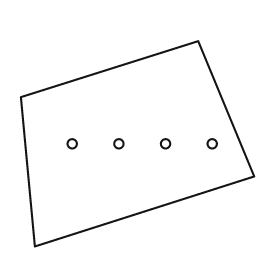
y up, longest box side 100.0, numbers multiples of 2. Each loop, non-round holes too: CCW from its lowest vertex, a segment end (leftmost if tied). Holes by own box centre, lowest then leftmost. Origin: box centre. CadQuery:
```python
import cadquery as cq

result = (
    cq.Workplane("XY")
    .moveTo(-44.0, -44.0)
    .lineTo(50.0, -14.0)
    .lineTo(26.0, 44.0)
    .lineTo(-50.0, 20.0)
    .close()
    .moveTo(-28.0, 0.0)
    .circle(2.0)
    .moveTo(-8.0, 0.0)
    .circle(2.0)
    .moveTo(12.0, 0.0)
    .circle(2.0)
    .moveTo(32.0, 0.0)
    .circle(2.0)
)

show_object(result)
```